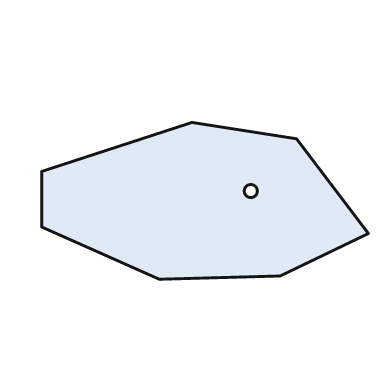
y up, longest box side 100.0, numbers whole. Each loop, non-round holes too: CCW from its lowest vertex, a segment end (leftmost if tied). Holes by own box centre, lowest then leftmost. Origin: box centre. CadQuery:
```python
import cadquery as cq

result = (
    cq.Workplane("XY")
    .moveTo(-14.0, -24.0)
    .lineTo(23.0, -23.0)
    .lineTo(50.0, -10.0)
    .lineTo(28.0, 19.0)
    .lineTo(-4.0, 24.0)
    .lineTo(-50.0, 9.0)
    .lineTo(-50.0, -8.0)
    .close()
    .moveTo(14.0, 3.0)
    .circle(2.0)
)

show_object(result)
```